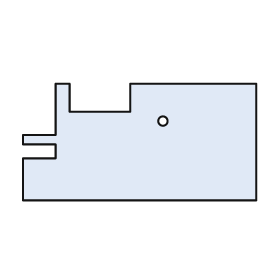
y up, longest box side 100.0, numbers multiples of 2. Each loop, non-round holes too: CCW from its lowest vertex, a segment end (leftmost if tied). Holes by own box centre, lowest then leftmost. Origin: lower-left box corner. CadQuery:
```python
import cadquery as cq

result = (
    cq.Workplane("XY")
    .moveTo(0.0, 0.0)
    .lineTo(100.0, 0.0)
    .lineTo(100.0, 50.0)
    .lineTo(46.0, 50.0)
    .lineTo(46.0, 38.0)
    .lineTo(20.0, 38.0)
    .lineTo(20.0, 50.0)
    .lineTo(14.0, 50.0)
    .lineTo(14.0, 28.0)
    .lineTo(0.0, 28.0)
    .lineTo(0.0, 24.0)
    .lineTo(14.0, 24.0)
    .lineTo(14.0, 18.0)
    .lineTo(0.0, 18.0)
    .close()
    .moveTo(60.0, 34.0)
    .circle(2.0)
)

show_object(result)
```